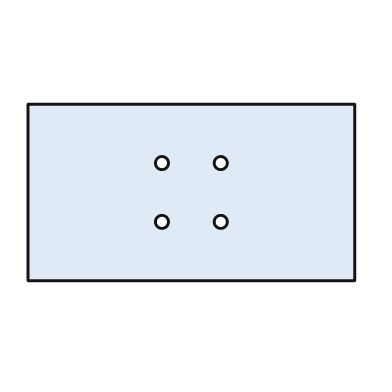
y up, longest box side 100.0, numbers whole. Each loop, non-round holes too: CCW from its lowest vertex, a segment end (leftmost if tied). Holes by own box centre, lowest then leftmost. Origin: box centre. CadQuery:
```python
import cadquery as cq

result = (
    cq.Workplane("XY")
    .moveTo(-50.0, -27.0)
    .lineTo(50.0, -27.0)
    .lineTo(50.0, 27.0)
    .lineTo(-50.0, 27.0)
    .close()
    .moveTo(-9.0, -9.0)
    .circle(2.0)
    .moveTo(9.0, -9.0)
    .circle(2.0)
    .moveTo(-9.0, 9.0)
    .circle(2.0)
    .moveTo(9.0, 9.0)
    .circle(2.0)
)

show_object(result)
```